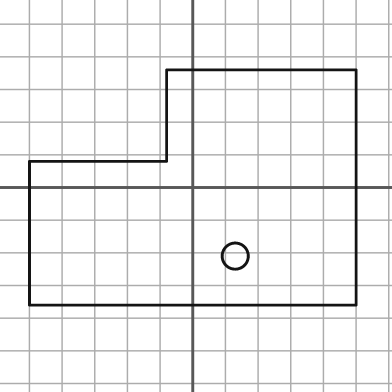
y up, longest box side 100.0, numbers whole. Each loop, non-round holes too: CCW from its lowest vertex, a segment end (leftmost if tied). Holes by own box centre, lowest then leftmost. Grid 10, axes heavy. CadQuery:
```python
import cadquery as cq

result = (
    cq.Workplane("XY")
    .moveTo(-50.0, -36.0)
    .lineTo(50.0, -36.0)
    .lineTo(50.0, 36.0)
    .lineTo(-8.0, 36.0)
    .lineTo(-8.0, 8.0)
    .lineTo(-50.0, 8.0)
    .close()
    .moveTo(13.0, -21.0)
    .circle(4.0)
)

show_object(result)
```